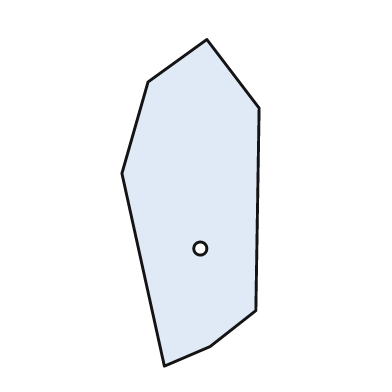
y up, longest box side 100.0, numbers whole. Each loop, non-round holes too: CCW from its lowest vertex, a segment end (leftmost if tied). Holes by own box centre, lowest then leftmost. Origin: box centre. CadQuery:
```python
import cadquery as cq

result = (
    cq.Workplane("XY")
    .moveTo(-8.0, -50.0)
    .lineTo(6.0, -44.0)
    .lineTo(20.0, -33.0)
    .lineTo(21.0, 29.0)
    .lineTo(5.0, 50.0)
    .lineTo(-13.0, 37.0)
    .lineTo(-21.0, 9.0)
    .close()
    .moveTo(3.0, -14.0)
    .circle(2.0)
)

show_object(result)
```